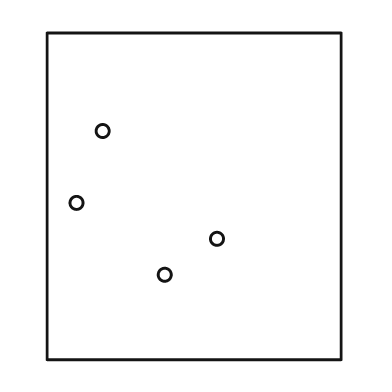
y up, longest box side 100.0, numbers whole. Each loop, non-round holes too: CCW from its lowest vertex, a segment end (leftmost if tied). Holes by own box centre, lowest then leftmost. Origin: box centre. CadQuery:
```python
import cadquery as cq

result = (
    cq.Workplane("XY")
    .moveTo(-45.0, -50.0)
    .lineTo(45.0, -50.0)
    .lineTo(45.0, 50.0)
    .lineTo(-45.0, 50.0)
    .close()
    .moveTo(-9.0, -24.0)
    .circle(2.0)
    .moveTo(7.0, -13.0)
    .circle(2.0)
    .moveTo(-36.0, -2.0)
    .circle(2.0)
    .moveTo(-28.0, 20.0)
    .circle(2.0)
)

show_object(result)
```